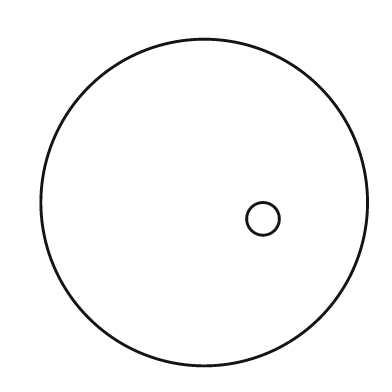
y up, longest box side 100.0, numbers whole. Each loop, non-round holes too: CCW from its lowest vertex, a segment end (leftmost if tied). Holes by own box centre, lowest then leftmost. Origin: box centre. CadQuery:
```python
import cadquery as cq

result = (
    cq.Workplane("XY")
    .moveTo(0.0, 0.0)
    .circle(50.0)
    .moveTo(18.0, -5.0)
    .circle(5.0)
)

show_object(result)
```